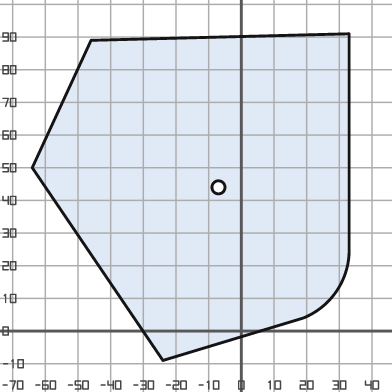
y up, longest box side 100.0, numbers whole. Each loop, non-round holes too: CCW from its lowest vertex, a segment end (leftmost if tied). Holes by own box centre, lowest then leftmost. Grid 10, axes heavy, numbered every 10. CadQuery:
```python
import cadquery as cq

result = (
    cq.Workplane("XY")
    .moveTo(-24.0, -9.0)
    .lineTo(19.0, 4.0)
    .threePointArc((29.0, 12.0), (33.0, 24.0))
    .lineTo(33.0, 91.0)
    .lineTo(-46.0, 89.0)
    .lineTo(-64.0, 50.0)
    .close()
    .moveTo(-7.0, 44.0)
    .circle(2.0)
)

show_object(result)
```